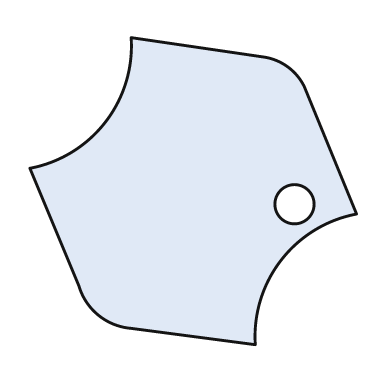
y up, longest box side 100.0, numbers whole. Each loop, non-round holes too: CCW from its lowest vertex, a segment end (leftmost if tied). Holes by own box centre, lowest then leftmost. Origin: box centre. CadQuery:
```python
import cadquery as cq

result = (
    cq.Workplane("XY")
    .moveTo(19.0, -47.0)
    .threePointArc((27.0, -21.0), (50.0, -7.0))
    .lineTo(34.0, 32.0)
    .threePointArc((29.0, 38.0), (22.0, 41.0))
    .lineTo(-19.0, 47.0)
    .threePointArc((-27.0, 21.0), (-50.0, 7.0))
    .lineTo(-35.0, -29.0)
    .threePointArc((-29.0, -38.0), (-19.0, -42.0))
    .close()
    .moveTo(31.0, -4.0)
    .circle(6.0)
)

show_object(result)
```